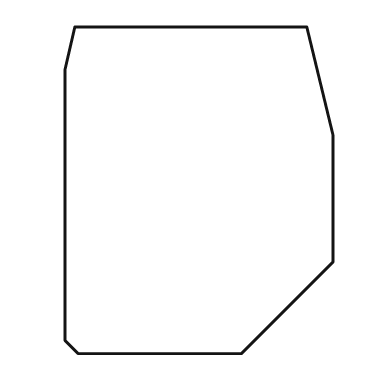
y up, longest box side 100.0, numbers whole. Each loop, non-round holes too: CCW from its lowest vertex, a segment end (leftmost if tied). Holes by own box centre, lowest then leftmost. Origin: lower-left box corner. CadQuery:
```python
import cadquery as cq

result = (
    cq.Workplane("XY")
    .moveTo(4.0, 0.0)
    .lineTo(54.0, 0.0)
    .lineTo(82.0, 28.0)
    .lineTo(82.0, 67.0)
    .lineTo(74.0, 100.0)
    .lineTo(3.0, 100.0)
    .lineTo(0.0, 87.0)
    .lineTo(0.0, 4.0)
    .close()
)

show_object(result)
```